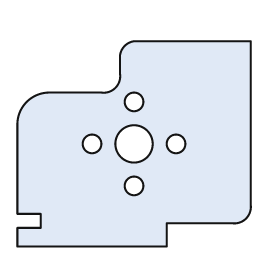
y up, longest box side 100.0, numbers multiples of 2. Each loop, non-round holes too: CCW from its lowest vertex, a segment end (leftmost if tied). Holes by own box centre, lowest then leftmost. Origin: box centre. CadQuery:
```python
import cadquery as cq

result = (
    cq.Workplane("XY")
    .moveTo(-50.0, -44.0)
    .lineTo(14.0, -44.0)
    .lineTo(14.0, -34.0)
    .lineTo(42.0, -34.0)
    .threePointArc((48.0, -32.0), (50.0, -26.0))
    .lineTo(50.0, 44.0)
    .lineTo(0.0, 44.0)
    .threePointArc((-4.0, 42.0), (-6.0, 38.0))
    .lineTo(-6.0, 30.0)
    .threePointArc((-8.0, 24.0), (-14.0, 22.0))
    .lineTo(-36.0, 22.0)
    .threePointArc((-46.0, 18.0), (-50.0, 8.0))
    .lineTo(-50.0, -30.0)
    .lineTo(-40.0, -30.0)
    .lineTo(-40.0, -36.0)
    .lineTo(-50.0, -36.0)
    .close()
    .moveTo(0.0, -18.0)
    .circle(4.0)
    .moveTo(-18.0, 0.0)
    .circle(4.0)
    .moveTo(0.0, 0.0)
    .circle(8.0)
    .moveTo(18.0, 0.0)
    .circle(4.0)
    .moveTo(0.0, 18.0)
    .circle(4.0)
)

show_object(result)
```